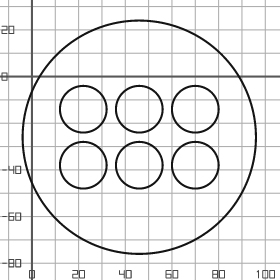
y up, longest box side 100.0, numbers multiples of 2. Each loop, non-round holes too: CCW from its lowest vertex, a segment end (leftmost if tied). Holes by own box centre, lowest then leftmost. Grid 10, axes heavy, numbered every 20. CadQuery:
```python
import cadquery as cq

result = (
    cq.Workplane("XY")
    .moveTo(46.0, -26.0)
    .circle(50.0)
    .moveTo(22.0, -38.0)
    .circle(10.0)
    .moveTo(46.0, -38.0)
    .circle(10.0)
    .moveTo(70.0, -38.0)
    .circle(10.0)
    .moveTo(22.0, -14.0)
    .circle(10.0)
    .moveTo(46.0, -14.0)
    .circle(10.0)
    .moveTo(70.0, -14.0)
    .circle(10.0)
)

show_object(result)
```